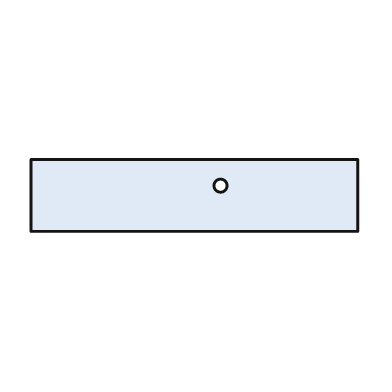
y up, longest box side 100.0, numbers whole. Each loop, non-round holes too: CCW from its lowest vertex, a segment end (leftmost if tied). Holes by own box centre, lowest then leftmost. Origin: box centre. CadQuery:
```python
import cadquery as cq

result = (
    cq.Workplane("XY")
    .moveTo(-50.0, -11.0)
    .lineTo(50.0, -11.0)
    .lineTo(50.0, 11.0)
    .lineTo(-50.0, 11.0)
    .close()
    .moveTo(8.0, 3.0)
    .circle(2.0)
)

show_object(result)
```